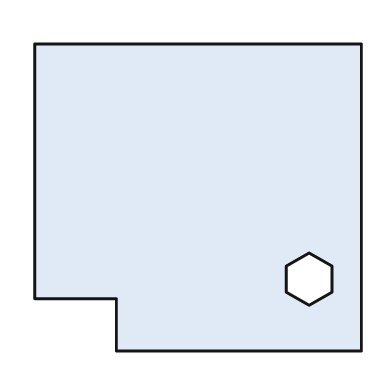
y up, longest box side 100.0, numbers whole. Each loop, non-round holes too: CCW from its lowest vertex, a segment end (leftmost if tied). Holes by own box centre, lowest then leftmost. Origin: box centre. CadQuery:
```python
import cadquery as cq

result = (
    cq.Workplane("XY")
    .moveTo(-25.0, -47.0)
    .lineTo(50.0, -47.0)
    .lineTo(50.0, 47.0)
    .lineTo(-50.0, 47.0)
    .lineTo(-50.0, -31.0)
    .lineTo(-25.0, -31.0)
    .close()
    .moveTo(34.0, -33.0)
    .lineTo(41.0, -29.0)
    .lineTo(41.0, -21.0)
    .lineTo(34.0, -17.0)
    .lineTo(27.0, -21.0)
    .lineTo(27.0, -29.0)
    .close()
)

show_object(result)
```